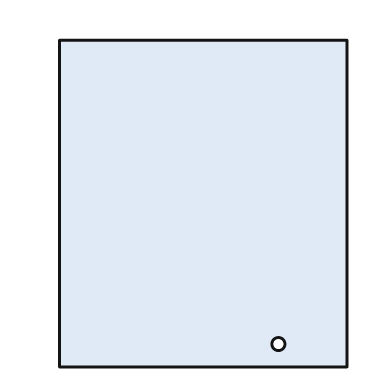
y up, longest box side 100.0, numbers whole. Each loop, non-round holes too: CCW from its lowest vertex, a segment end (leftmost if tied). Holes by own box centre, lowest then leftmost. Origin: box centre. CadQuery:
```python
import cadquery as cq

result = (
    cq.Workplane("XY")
    .moveTo(-44.0, -50.0)
    .lineTo(44.0, -50.0)
    .lineTo(44.0, 50.0)
    .lineTo(-44.0, 50.0)
    .close()
    .moveTo(23.0, -43.0)
    .circle(2.0)
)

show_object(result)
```